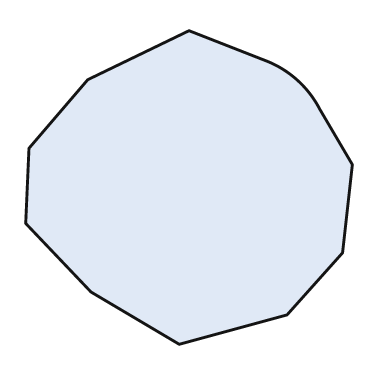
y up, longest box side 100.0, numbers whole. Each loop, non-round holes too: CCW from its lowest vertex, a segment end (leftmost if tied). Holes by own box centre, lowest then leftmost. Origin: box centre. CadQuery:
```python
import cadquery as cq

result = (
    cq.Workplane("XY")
    .moveTo(-3.0, -48.0)
    .lineTo(30.0, -39.0)
    .lineTo(47.0, -20.0)
    .lineTo(50.0, 7.0)
    .lineTo(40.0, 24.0)
    .threePointArc((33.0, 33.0), (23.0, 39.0))
    .lineTo(0.0, 48.0)
    .lineTo(-31.0, 33.0)
    .lineTo(-49.0, 12.0)
    .lineTo(-50.0, -11.0)
    .lineTo(-30.0, -32.0)
    .close()
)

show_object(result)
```